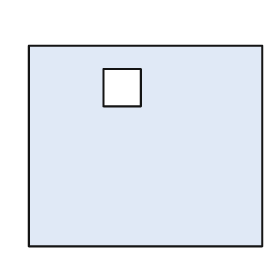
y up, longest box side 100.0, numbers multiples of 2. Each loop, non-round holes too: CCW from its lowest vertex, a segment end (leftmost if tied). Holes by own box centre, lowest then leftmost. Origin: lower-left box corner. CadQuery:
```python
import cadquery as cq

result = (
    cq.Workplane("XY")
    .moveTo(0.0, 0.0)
    .lineTo(100.0, 0.0)
    .lineTo(100.0, 86.0)
    .lineTo(0.0, 86.0)
    .close()
    .moveTo(32.0, 60.0)
    .lineTo(48.0, 60.0)
    .lineTo(48.0, 76.0)
    .lineTo(32.0, 76.0)
    .close()
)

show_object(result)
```